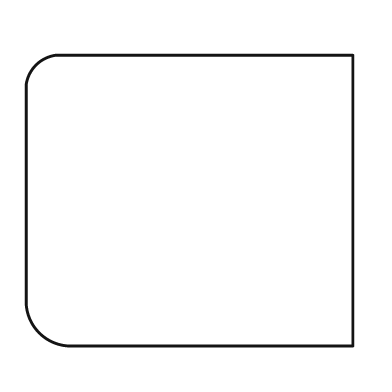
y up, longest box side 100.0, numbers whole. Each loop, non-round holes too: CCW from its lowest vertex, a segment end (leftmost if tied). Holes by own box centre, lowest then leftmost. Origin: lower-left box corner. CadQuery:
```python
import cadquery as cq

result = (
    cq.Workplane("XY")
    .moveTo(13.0, 0.0)
    .lineTo(100.0, 0.0)
    .lineTo(100.0, 89.0)
    .lineTo(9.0, 89.0)
    .threePointArc((3.0, 86.0), (0.0, 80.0))
    .lineTo(0.0, 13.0)
    .threePointArc((4.0, 4.0), (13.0, 0.0))
    .close()
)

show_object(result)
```